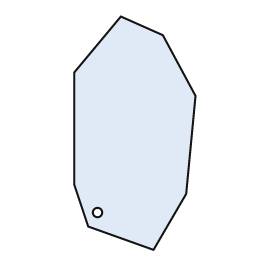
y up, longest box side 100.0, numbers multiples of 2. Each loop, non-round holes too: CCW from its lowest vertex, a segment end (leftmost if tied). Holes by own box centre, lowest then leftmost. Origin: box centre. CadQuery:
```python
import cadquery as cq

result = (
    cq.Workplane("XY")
    .moveTo(8.0, -50.0)
    .lineTo(22.0, -26.0)
    .lineTo(26.0, 16.0)
    .lineTo(12.0, 42.0)
    .lineTo(-6.0, 50.0)
    .lineTo(-26.0, 26.0)
    .lineTo(-26.0, -22.0)
    .lineTo(-20.0, -40.0)
    .close()
    .moveTo(-16.0, -34.0)
    .circle(2.0)
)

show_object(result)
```